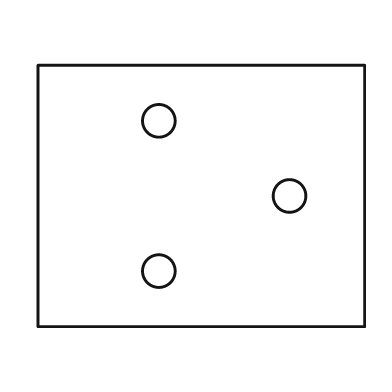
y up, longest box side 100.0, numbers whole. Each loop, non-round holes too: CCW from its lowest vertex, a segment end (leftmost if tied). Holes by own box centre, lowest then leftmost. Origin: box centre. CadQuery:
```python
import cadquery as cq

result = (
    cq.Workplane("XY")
    .moveTo(-50.0, -40.0)
    .lineTo(50.0, -40.0)
    .lineTo(50.0, 40.0)
    .lineTo(-50.0, 40.0)
    .close()
    .moveTo(-13.0, -23.0)
    .circle(5.0)
    .moveTo(27.0, 0.0)
    .circle(5.0)
    .moveTo(-13.0, 23.0)
    .circle(5.0)
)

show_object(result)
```